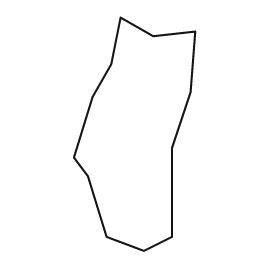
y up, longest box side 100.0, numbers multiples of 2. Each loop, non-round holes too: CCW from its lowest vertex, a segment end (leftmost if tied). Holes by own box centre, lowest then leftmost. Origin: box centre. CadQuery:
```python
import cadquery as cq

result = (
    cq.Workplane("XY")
    .moveTo(4.0, -50.0)
    .lineTo(16.0, -44.0)
    .lineTo(16.0, -6.0)
    .lineTo(24.0, 18.0)
    .lineTo(26.0, 44.0)
    .lineTo(8.0, 42.0)
    .lineTo(-6.0, 50.0)
    .lineTo(-10.0, 30.0)
    .lineTo(-18.0, 16.0)
    .lineTo(-26.0, -10.0)
    .lineTo(-20.0, -18.0)
    .lineTo(-12.0, -44.0)
    .close()
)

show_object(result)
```